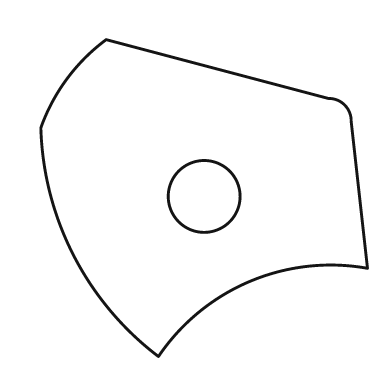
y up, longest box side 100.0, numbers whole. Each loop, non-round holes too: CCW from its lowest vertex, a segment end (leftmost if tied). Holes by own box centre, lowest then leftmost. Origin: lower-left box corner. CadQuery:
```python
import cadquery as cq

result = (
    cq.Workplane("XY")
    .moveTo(36.0, 0.0)
    .threePointArc((64.0, 23.0), (100.0, 27.0))
    .lineTo(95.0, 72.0)
    .threePointArc((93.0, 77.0), (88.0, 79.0))
    .lineTo(20.0, 97.0)
    .threePointArc((8.0, 85.0), (0.0, 70.0))
    .threePointArc((10.0, 31.0), (36.0, 0.0))
    .close()
    .moveTo(50.0, 49.0)
    .circle(11.0)
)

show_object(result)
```